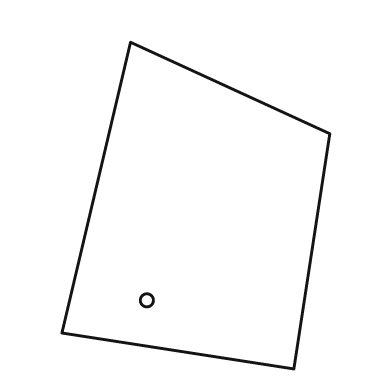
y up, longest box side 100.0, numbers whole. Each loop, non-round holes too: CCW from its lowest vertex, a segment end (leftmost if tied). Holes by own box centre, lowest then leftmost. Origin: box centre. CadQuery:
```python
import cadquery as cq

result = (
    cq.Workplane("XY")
    .moveTo(30.0, -50.0)
    .lineTo(41.0, 22.0)
    .lineTo(-20.0, 50.0)
    .lineTo(-41.0, -39.0)
    .close()
    .moveTo(-15.0, -29.0)
    .circle(2.0)
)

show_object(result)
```